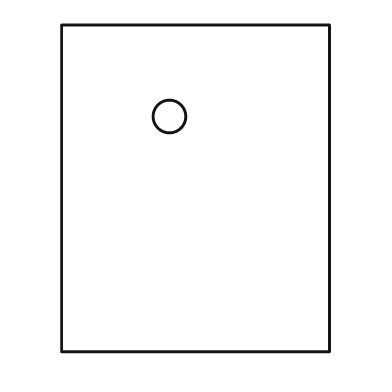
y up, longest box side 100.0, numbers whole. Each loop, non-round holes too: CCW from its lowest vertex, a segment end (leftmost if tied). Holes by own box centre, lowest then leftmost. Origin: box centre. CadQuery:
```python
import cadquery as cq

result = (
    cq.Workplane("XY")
    .moveTo(-41.0, -50.0)
    .lineTo(41.0, -50.0)
    .lineTo(41.0, 50.0)
    .lineTo(-41.0, 50.0)
    .close()
    .moveTo(-8.0, 22.0)
    .circle(5.0)
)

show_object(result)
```